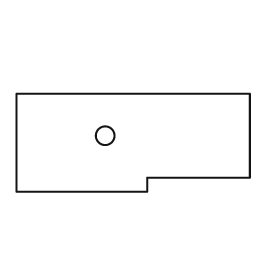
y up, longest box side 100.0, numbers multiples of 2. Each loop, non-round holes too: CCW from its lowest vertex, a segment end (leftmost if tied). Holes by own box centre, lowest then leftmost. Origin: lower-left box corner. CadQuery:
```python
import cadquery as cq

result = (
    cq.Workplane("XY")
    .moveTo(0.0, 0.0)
    .lineTo(56.0, 0.0)
    .lineTo(56.0, 6.0)
    .lineTo(100.0, 6.0)
    .lineTo(100.0, 42.0)
    .lineTo(0.0, 42.0)
    .close()
    .moveTo(38.0, 24.0)
    .circle(4.0)
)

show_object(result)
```